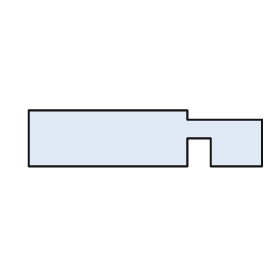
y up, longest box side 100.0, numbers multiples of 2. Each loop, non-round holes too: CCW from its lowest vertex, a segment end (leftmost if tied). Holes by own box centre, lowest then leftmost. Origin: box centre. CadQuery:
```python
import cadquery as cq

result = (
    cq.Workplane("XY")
    .moveTo(-50.0, -12.0)
    .lineTo(18.0, -12.0)
    .lineTo(18.0, 0.0)
    .lineTo(28.0, 0.0)
    .lineTo(28.0, -12.0)
    .lineTo(50.0, -12.0)
    .lineTo(50.0, 8.0)
    .lineTo(18.0, 8.0)
    .lineTo(18.0, 12.0)
    .lineTo(-50.0, 12.0)
    .close()
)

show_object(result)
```